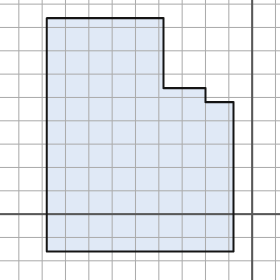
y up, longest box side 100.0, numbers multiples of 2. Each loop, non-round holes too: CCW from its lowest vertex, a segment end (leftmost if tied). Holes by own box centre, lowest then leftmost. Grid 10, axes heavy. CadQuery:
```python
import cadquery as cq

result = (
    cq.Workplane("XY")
    .moveTo(-88.0, -16.0)
    .lineTo(-8.0, -16.0)
    .lineTo(-8.0, 48.0)
    .lineTo(-20.0, 48.0)
    .lineTo(-20.0, 54.0)
    .lineTo(-38.0, 54.0)
    .lineTo(-38.0, 84.0)
    .lineTo(-88.0, 84.0)
    .close()
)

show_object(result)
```